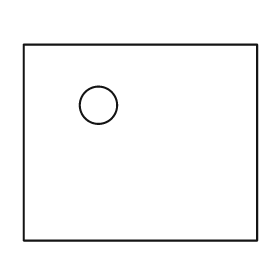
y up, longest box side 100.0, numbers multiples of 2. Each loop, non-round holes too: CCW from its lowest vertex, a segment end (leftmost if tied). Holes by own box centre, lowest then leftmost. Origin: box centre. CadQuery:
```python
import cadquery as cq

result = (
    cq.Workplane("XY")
    .moveTo(-50.0, -42.0)
    .lineTo(50.0, -42.0)
    .lineTo(50.0, 42.0)
    .lineTo(-50.0, 42.0)
    .close()
    .moveTo(-18.0, 16.0)
    .circle(8.0)
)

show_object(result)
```